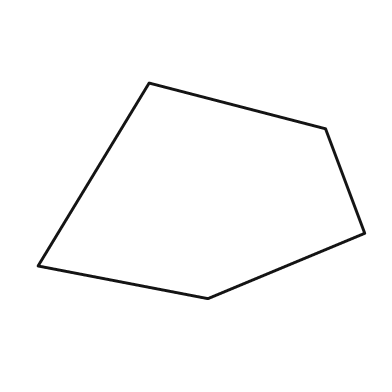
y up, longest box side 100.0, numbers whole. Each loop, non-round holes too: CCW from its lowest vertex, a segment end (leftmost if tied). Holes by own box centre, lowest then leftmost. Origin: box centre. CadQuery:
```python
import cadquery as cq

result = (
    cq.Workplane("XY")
    .moveTo(2.0, -33.0)
    .lineTo(50.0, -13.0)
    .lineTo(38.0, 19.0)
    .lineTo(-16.0, 33.0)
    .lineTo(-50.0, -23.0)
    .close()
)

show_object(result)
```